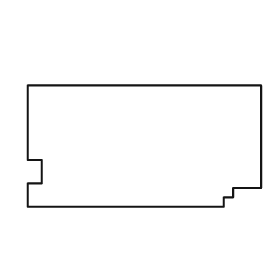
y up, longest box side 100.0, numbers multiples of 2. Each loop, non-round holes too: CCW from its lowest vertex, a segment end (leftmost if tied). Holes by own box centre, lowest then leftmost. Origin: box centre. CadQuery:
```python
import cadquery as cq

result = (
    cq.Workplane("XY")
    .moveTo(-50.0, -26.0)
    .lineTo(34.0, -26.0)
    .lineTo(34.0, -22.0)
    .lineTo(38.0, -22.0)
    .lineTo(38.0, -18.0)
    .lineTo(50.0, -18.0)
    .lineTo(50.0, 26.0)
    .lineTo(-50.0, 26.0)
    .lineTo(-50.0, -6.0)
    .lineTo(-44.0, -6.0)
    .lineTo(-44.0, -16.0)
    .lineTo(-50.0, -16.0)
    .close()
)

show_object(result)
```